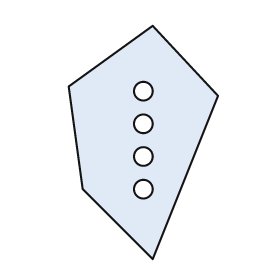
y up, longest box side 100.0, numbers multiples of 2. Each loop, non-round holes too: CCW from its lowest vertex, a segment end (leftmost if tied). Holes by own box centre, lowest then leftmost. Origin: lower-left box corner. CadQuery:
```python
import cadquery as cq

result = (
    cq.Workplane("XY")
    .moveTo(36.0, 0.0)
    .lineTo(64.0, 70.0)
    .lineTo(36.0, 100.0)
    .lineTo(0.0, 74.0)
    .lineTo(6.0, 30.0)
    .close()
    .moveTo(32.0, 30.0)
    .circle(4.0)
    .moveTo(32.0, 44.0)
    .circle(4.0)
    .moveTo(32.0, 58.0)
    .circle(4.0)
    .moveTo(32.0, 72.0)
    .circle(4.0)
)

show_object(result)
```